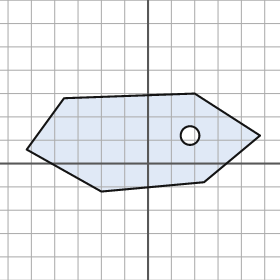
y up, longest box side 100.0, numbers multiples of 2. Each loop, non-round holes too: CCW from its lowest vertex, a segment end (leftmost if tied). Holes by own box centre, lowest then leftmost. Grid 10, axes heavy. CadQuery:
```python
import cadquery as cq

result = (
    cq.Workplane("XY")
    .moveTo(-20.0, -12.0)
    .lineTo(24.0, -8.0)
    .lineTo(48.0, 12.0)
    .lineTo(20.0, 30.0)
    .lineTo(-36.0, 28.0)
    .lineTo(-52.0, 6.0)
    .close()
    .moveTo(18.0, 12.0)
    .circle(4.0)
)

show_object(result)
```